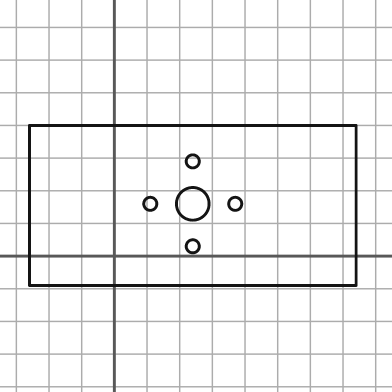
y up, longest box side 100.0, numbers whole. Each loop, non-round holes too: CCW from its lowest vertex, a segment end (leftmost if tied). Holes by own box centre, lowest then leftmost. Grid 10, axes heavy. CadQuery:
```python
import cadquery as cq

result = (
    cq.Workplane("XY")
    .moveTo(-26.0, -9.0)
    .lineTo(74.0, -9.0)
    .lineTo(74.0, 40.0)
    .lineTo(-26.0, 40.0)
    .close()
    .moveTo(24.0, 3.0)
    .circle(2.0)
    .moveTo(11.0, 16.0)
    .circle(2.0)
    .moveTo(24.0, 16.0)
    .circle(5.0)
    .moveTo(37.0, 16.0)
    .circle(2.0)
    .moveTo(24.0, 29.0)
    .circle(2.0)
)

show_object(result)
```